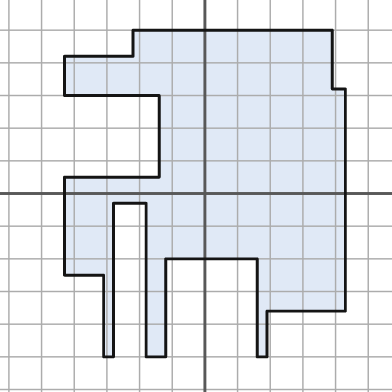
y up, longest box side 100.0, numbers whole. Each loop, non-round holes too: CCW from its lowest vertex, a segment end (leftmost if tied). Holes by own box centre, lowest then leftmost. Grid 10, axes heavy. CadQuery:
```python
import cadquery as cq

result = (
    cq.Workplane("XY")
    .moveTo(-31.0, -50.0)
    .lineTo(-28.0, -50.0)
    .lineTo(-28.0, -3.0)
    .lineTo(-18.0, -3.0)
    .lineTo(-18.0, -50.0)
    .lineTo(-12.0, -50.0)
    .lineTo(-12.0, -20.0)
    .lineTo(16.0, -20.0)
    .lineTo(16.0, -50.0)
    .lineTo(19.0, -50.0)
    .lineTo(19.0, -36.0)
    .lineTo(43.0, -36.0)
    .lineTo(43.0, 32.0)
    .lineTo(39.0, 32.0)
    .lineTo(39.0, 50.0)
    .lineTo(-22.0, 50.0)
    .lineTo(-22.0, 42.0)
    .lineTo(-43.0, 42.0)
    .lineTo(-43.0, 30.0)
    .lineTo(-14.0, 30.0)
    .lineTo(-14.0, 5.0)
    .lineTo(-43.0, 5.0)
    .lineTo(-43.0, -25.0)
    .lineTo(-31.0, -25.0)
    .close()
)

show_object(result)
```